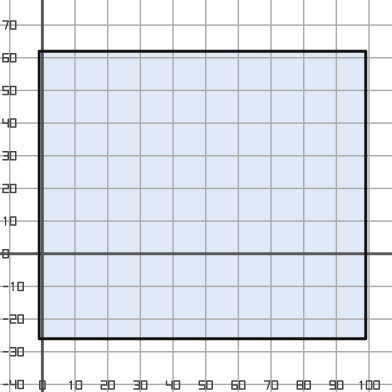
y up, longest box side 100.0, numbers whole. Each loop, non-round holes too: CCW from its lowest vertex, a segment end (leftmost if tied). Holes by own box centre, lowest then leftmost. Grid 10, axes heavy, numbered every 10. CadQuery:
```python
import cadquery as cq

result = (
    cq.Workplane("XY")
    .moveTo(-1.0, -26.0)
    .lineTo(99.0, -26.0)
    .lineTo(99.0, 62.0)
    .lineTo(-1.0, 62.0)
    .close()
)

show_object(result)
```